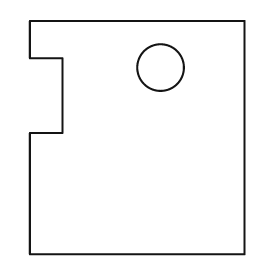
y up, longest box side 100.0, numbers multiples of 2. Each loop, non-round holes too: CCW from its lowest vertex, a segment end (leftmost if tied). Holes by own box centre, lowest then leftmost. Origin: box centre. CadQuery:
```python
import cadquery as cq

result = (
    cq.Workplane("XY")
    .moveTo(-46.0, -50.0)
    .lineTo(46.0, -50.0)
    .lineTo(46.0, 50.0)
    .lineTo(-46.0, 50.0)
    .lineTo(-46.0, 34.0)
    .lineTo(-32.0, 34.0)
    .lineTo(-32.0, 2.0)
    .lineTo(-46.0, 2.0)
    .close()
    .moveTo(10.0, 30.0)
    .circle(10.0)
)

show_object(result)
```